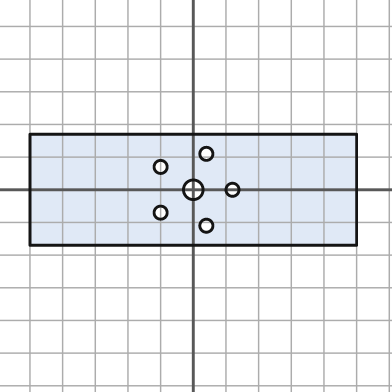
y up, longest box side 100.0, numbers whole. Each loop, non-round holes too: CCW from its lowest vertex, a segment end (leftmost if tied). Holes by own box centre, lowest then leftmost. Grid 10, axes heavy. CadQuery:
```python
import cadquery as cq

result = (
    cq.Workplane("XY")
    .moveTo(-50.0, -17.0)
    .lineTo(50.0, -17.0)
    .lineTo(50.0, 17.0)
    .lineTo(-50.0, 17.0)
    .close()
    .moveTo(4.0, -11.0)
    .circle(2.0)
    .moveTo(-10.0, -7.0)
    .circle(2.0)
    .moveTo(0.0, 0.0)
    .circle(3.0)
    .moveTo(12.0, 0.0)
    .circle(2.0)
    .moveTo(-10.0, 7.0)
    .circle(2.0)
    .moveTo(4.0, 11.0)
    .circle(2.0)
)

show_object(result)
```